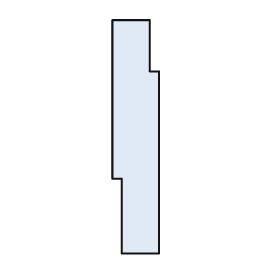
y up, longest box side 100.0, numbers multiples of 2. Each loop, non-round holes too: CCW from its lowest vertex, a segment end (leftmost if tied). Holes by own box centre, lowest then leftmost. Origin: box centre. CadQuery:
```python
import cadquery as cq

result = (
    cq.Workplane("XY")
    .moveTo(-6.0, -50.0)
    .lineTo(10.0, -50.0)
    .lineTo(10.0, 28.0)
    .lineTo(6.0, 28.0)
    .lineTo(6.0, 50.0)
    .lineTo(-10.0, 50.0)
    .lineTo(-10.0, -18.0)
    .lineTo(-6.0, -18.0)
    .close()
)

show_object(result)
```